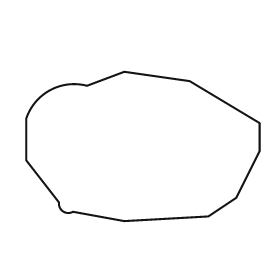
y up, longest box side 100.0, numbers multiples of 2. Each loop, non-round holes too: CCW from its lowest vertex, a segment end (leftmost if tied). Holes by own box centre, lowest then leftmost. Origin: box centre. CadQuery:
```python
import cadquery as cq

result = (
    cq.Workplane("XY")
    .moveTo(-8.0, -32.0)
    .lineTo(28.0, -30.0)
    .lineTo(40.0, -22.0)
    .lineTo(50.0, -2.0)
    .lineTo(50.0, 10.0)
    .lineTo(20.0, 28.0)
    .lineTo(-8.0, 32.0)
    .lineTo(-24.0, 26.0)
    .threePointArc((-40.0, 24.0), (-50.0, 12.0))
    .lineTo(-50.0, -6.0)
    .lineTo(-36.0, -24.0)
    .threePointArc((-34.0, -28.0), (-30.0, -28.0))
    .close()
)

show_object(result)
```